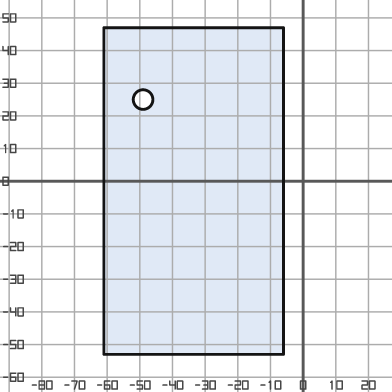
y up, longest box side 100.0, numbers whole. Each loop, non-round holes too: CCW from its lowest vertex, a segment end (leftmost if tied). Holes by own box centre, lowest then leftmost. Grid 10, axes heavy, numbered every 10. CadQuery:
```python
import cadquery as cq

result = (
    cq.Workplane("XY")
    .moveTo(-61.0, -53.0)
    .lineTo(-6.0, -53.0)
    .lineTo(-6.0, 47.0)
    .lineTo(-61.0, 47.0)
    .close()
    .moveTo(-49.0, 25.0)
    .circle(3.0)
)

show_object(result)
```